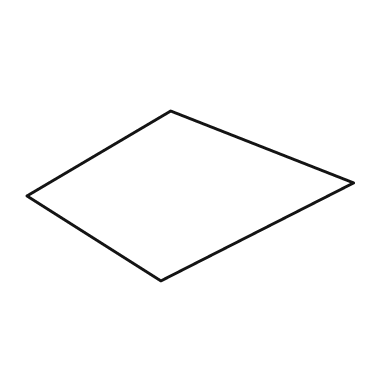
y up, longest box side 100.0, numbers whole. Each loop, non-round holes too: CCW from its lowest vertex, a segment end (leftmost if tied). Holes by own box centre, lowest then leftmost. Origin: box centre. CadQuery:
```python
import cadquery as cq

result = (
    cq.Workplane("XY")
    .moveTo(-9.0, -26.0)
    .lineTo(50.0, 4.0)
    .lineTo(-6.0, 26.0)
    .lineTo(-50.0, 0.0)
    .close()
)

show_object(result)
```